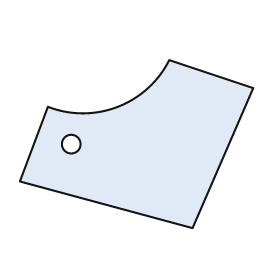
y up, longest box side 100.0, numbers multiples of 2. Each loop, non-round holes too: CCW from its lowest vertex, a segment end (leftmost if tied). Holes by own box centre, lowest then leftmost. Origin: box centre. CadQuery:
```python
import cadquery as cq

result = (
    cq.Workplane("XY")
    .moveTo(24.0, -36.0)
    .lineTo(50.0, 24.0)
    .lineTo(14.0, 36.0)
    .threePointArc((-8.0, 16.0), (-38.0, 16.0))
    .lineTo(-50.0, -16.0)
    .close()
    .moveTo(-28.0, 0.0)
    .circle(4.0)
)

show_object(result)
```